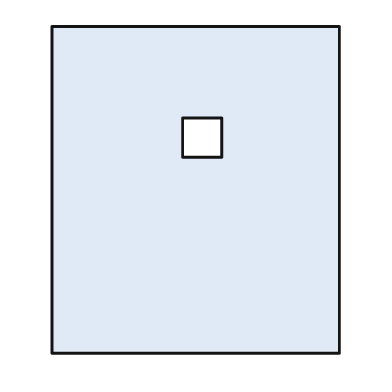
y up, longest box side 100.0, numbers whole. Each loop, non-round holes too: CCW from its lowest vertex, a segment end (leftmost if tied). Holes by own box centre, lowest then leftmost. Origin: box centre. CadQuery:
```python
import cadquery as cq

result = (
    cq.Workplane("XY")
    .moveTo(-44.0, -50.0)
    .lineTo(44.0, -50.0)
    .lineTo(44.0, 50.0)
    .lineTo(-44.0, 50.0)
    .close()
    .moveTo(-4.0, 10.0)
    .lineTo(8.0, 10.0)
    .lineTo(8.0, 22.0)
    .lineTo(-4.0, 22.0)
    .close()
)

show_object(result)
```